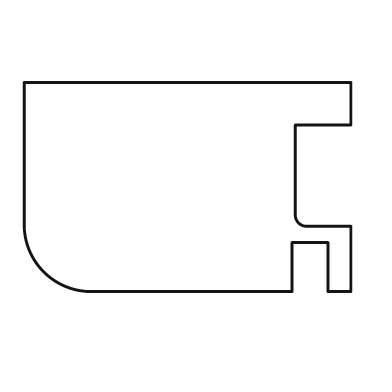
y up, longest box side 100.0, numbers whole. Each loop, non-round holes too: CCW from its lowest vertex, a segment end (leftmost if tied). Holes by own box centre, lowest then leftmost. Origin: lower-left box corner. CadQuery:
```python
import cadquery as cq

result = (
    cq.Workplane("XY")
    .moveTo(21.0, 0.0)
    .lineTo(82.0, 0.0)
    .lineTo(82.0, 15.0)
    .lineTo(93.0, 15.0)
    .lineTo(93.0, 0.0)
    .lineTo(100.0, 0.0)
    .lineTo(100.0, 20.0)
    .lineTo(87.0, 20.0)
    .threePointArc((84.0, 21.0), (83.0, 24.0))
    .lineTo(83.0, 51.0)
    .lineTo(100.0, 51.0)
    .lineTo(100.0, 64.0)
    .lineTo(0.0, 64.0)
    .lineTo(0.0, 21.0)
    .threePointArc((6.0, 6.0), (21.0, 0.0))
    .close()
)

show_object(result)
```